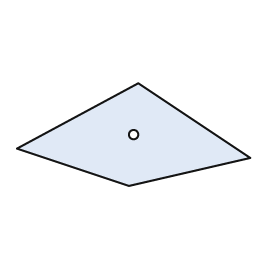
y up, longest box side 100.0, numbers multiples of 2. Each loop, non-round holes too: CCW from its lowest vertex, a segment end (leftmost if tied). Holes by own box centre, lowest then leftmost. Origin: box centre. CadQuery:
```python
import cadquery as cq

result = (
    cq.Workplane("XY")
    .moveTo(-2.0, -22.0)
    .lineTo(50.0, -10.0)
    .lineTo(2.0, 22.0)
    .lineTo(-50.0, -6.0)
    .close()
    .moveTo(0.0, 0.0)
    .circle(2.0)
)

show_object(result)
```